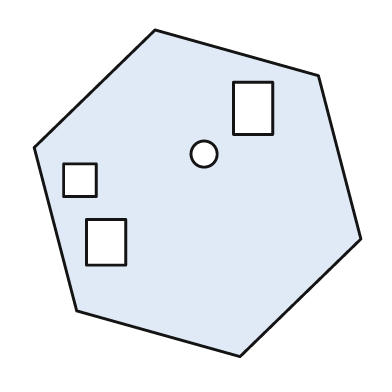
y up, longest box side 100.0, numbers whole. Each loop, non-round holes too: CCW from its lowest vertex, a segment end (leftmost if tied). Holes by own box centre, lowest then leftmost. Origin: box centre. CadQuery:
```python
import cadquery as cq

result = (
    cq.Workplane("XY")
    .moveTo(13.0, -50.0)
    .lineTo(50.0, -14.0)
    .lineTo(37.0, 36.0)
    .lineTo(-13.0, 50.0)
    .lineTo(-50.0, 14.0)
    .lineTo(-37.0, -36.0)
    .close()
    .moveTo(-34.0, -22.0)
    .lineTo(-22.0, -22.0)
    .lineTo(-22.0, -8.0)
    .lineTo(-34.0, -8.0)
    .close()
    .moveTo(-41.0, -1.0)
    .lineTo(-31.0, -1.0)
    .lineTo(-31.0, 9.0)
    .lineTo(-41.0, 9.0)
    .close()
    .moveTo(2.0, 12.0)
    .circle(4.0)
    .moveTo(11.0, 18.0)
    .lineTo(23.0, 18.0)
    .lineTo(23.0, 34.0)
    .lineTo(11.0, 34.0)
    .close()
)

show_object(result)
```